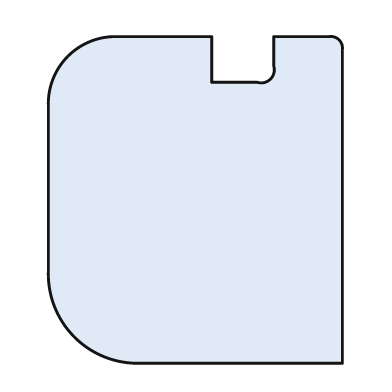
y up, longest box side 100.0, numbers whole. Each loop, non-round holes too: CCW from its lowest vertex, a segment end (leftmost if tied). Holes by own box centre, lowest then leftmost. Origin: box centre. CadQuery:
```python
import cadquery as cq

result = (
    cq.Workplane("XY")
    .moveTo(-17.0, -50.0)
    .lineTo(45.0, -50.0)
    .lineTo(45.0, 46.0)
    .threePointArc((44.0, 49.0), (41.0, 50.0))
    .lineTo(24.0, 50.0)
    .lineTo(24.0, 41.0)
    .threePointArc((23.0, 37.0), (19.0, 36.0))
    .lineTo(5.0, 36.0)
    .lineTo(5.0, 50.0)
    .lineTo(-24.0, 50.0)
    .threePointArc((-39.0, 44.0), (-45.0, 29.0))
    .lineTo(-45.0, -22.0)
    .threePointArc((-37.0, -42.0), (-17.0, -50.0))
    .close()
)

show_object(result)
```